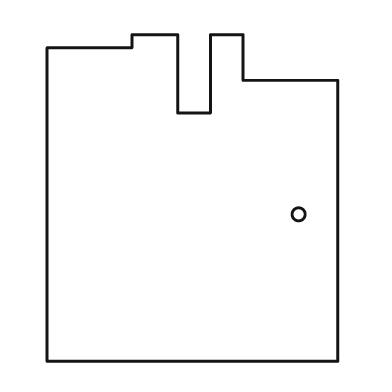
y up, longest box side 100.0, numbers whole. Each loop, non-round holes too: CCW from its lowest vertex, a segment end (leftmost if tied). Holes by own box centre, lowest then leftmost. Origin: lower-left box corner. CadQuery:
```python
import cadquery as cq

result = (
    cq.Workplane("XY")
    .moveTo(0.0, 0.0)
    .lineTo(89.0, 0.0)
    .lineTo(89.0, 86.0)
    .lineTo(60.0, 86.0)
    .lineTo(60.0, 100.0)
    .lineTo(50.0, 100.0)
    .lineTo(50.0, 76.0)
    .lineTo(40.0, 76.0)
    .lineTo(40.0, 100.0)
    .lineTo(26.0, 100.0)
    .lineTo(26.0, 96.0)
    .lineTo(0.0, 96.0)
    .close()
    .moveTo(77.0, 45.0)
    .circle(2.0)
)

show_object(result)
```